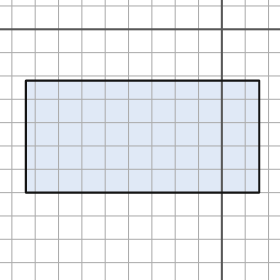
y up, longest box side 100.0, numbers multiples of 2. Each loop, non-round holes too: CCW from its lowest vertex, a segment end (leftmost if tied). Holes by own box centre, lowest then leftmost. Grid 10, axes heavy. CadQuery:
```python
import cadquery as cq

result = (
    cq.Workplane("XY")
    .moveTo(-84.0, -70.0)
    .lineTo(16.0, -70.0)
    .lineTo(16.0, -22.0)
    .lineTo(-84.0, -22.0)
    .close()
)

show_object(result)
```